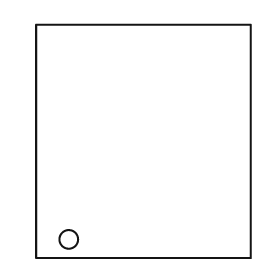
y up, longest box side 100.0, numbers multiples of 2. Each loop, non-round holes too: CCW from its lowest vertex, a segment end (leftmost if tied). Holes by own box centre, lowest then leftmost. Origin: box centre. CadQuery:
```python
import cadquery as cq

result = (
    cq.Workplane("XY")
    .moveTo(-46.0, -50.0)
    .lineTo(46.0, -50.0)
    .lineTo(46.0, 50.0)
    .lineTo(-46.0, 50.0)
    .close()
    .moveTo(-32.0, -42.0)
    .circle(4.0)
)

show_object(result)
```